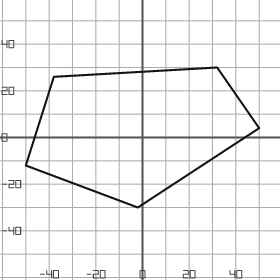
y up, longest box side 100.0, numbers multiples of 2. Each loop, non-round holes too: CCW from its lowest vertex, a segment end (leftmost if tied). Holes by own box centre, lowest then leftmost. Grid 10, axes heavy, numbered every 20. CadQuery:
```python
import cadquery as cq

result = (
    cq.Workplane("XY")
    .moveTo(-2.0, -30.0)
    .lineTo(50.0, 4.0)
    .lineTo(32.0, 30.0)
    .lineTo(-38.0, 26.0)
    .lineTo(-50.0, -12.0)
    .close()
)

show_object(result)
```